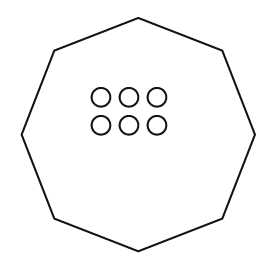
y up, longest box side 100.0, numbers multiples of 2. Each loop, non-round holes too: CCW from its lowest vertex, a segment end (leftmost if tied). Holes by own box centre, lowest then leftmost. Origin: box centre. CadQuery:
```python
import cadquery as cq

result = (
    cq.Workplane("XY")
    .moveTo(0.0, -50.0)
    .lineTo(36.0, -36.0)
    .lineTo(50.0, 0.0)
    .lineTo(36.0, 36.0)
    .lineTo(0.0, 50.0)
    .lineTo(-36.0, 36.0)
    .lineTo(-50.0, 0.0)
    .lineTo(-36.0, -36.0)
    .close()
    .moveTo(-16.0, 4.0)
    .circle(4.0)
    .moveTo(-4.0, 4.0)
    .circle(4.0)
    .moveTo(8.0, 4.0)
    .circle(4.0)
    .moveTo(-16.0, 16.0)
    .circle(4.0)
    .moveTo(-4.0, 16.0)
    .circle(4.0)
    .moveTo(8.0, 16.0)
    .circle(4.0)
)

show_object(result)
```